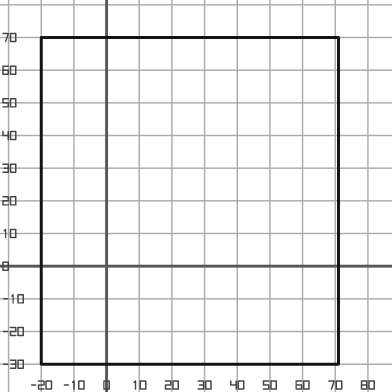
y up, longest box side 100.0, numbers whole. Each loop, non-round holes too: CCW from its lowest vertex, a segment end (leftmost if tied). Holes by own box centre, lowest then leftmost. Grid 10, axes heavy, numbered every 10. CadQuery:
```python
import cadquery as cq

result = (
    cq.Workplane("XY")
    .moveTo(-20.0, -30.0)
    .lineTo(71.0, -30.0)
    .lineTo(71.0, 70.0)
    .lineTo(-20.0, 70.0)
    .close()
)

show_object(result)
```